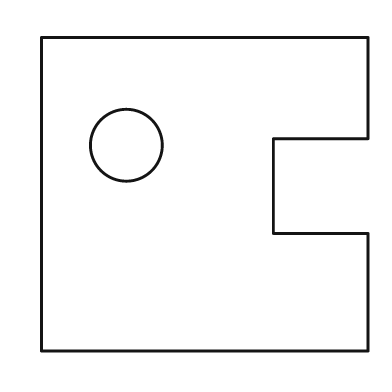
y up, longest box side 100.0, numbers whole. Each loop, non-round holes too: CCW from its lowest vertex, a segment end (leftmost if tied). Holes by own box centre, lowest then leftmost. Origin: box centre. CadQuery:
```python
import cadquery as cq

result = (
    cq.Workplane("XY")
    .moveTo(-50.0, -48.0)
    .lineTo(50.0, -48.0)
    .lineTo(50.0, -12.0)
    .lineTo(21.0, -12.0)
    .lineTo(21.0, 17.0)
    .lineTo(50.0, 17.0)
    .lineTo(50.0, 48.0)
    .lineTo(-50.0, 48.0)
    .close()
    .moveTo(-24.0, 15.0)
    .circle(11.0)
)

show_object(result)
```